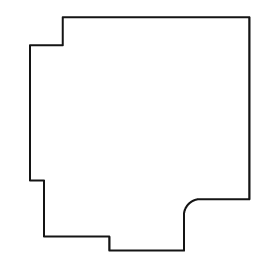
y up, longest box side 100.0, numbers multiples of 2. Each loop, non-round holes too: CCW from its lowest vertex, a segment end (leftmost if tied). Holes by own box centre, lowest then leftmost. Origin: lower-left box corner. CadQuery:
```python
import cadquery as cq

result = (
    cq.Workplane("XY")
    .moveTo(34.0, 0.0)
    .lineTo(66.0, 0.0)
    .lineTo(66.0, 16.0)
    .threePointArc((68.0, 20.0), (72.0, 22.0))
    .lineTo(94.0, 22.0)
    .lineTo(94.0, 100.0)
    .lineTo(14.0, 100.0)
    .lineTo(14.0, 88.0)
    .lineTo(0.0, 88.0)
    .lineTo(0.0, 30.0)
    .lineTo(6.0, 30.0)
    .lineTo(6.0, 6.0)
    .lineTo(34.0, 6.0)
    .close()
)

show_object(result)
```